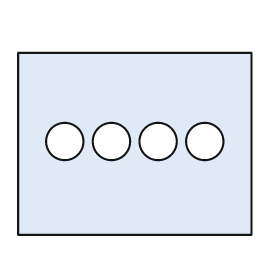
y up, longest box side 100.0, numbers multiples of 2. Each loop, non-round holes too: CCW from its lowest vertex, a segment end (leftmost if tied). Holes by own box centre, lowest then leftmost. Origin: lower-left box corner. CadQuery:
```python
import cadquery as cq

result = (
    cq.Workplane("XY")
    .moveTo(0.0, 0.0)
    .lineTo(100.0, 0.0)
    .lineTo(100.0, 78.0)
    .lineTo(0.0, 78.0)
    .close()
    .moveTo(20.0, 40.0)
    .circle(8.0)
    .moveTo(40.0, 40.0)
    .circle(8.0)
    .moveTo(60.0, 40.0)
    .circle(8.0)
    .moveTo(80.0, 40.0)
    .circle(8.0)
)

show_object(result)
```